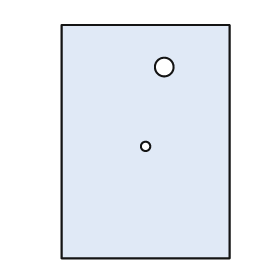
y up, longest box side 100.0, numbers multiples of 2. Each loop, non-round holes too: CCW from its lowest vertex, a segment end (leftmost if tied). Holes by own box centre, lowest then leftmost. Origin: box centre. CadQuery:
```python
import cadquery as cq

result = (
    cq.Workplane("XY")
    .moveTo(-36.0, -50.0)
    .lineTo(36.0, -50.0)
    .lineTo(36.0, 50.0)
    .lineTo(-36.0, 50.0)
    .close()
    .moveTo(0.0, -2.0)
    .circle(2.0)
    .moveTo(8.0, 32.0)
    .circle(4.0)
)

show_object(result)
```